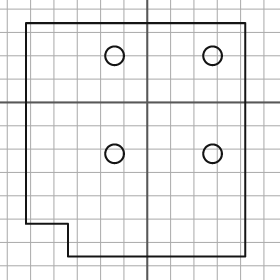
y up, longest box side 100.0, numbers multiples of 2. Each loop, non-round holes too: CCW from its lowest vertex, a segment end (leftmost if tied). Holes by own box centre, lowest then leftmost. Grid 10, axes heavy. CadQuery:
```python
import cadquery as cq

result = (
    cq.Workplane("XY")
    .moveTo(-34.0, -66.0)
    .lineTo(42.0, -66.0)
    .lineTo(42.0, 34.0)
    .lineTo(-52.0, 34.0)
    .lineTo(-52.0, -52.0)
    .lineTo(-34.0, -52.0)
    .close()
    .moveTo(-14.0, -22.0)
    .circle(4.0)
    .moveTo(28.0, -22.0)
    .circle(4.0)
    .moveTo(-14.0, 20.0)
    .circle(4.0)
    .moveTo(28.0, 20.0)
    .circle(4.0)
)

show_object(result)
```